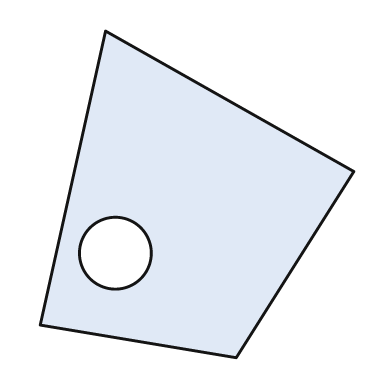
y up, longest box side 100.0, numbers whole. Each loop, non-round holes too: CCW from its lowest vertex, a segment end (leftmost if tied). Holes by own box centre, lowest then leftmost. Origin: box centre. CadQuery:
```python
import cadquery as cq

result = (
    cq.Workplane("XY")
    .moveTo(12.0, -50.0)
    .lineTo(48.0, 7.0)
    .lineTo(-28.0, 50.0)
    .lineTo(-48.0, -40.0)
    .close()
    .moveTo(-25.0, -18.0)
    .circle(11.0)
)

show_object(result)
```